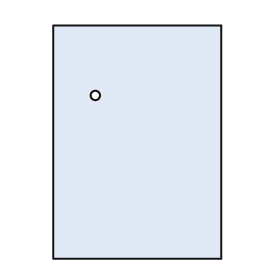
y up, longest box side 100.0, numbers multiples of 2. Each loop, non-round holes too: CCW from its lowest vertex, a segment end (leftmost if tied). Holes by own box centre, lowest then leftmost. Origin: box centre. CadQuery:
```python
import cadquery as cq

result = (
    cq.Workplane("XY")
    .moveTo(-36.0, -50.0)
    .lineTo(36.0, -50.0)
    .lineTo(36.0, 50.0)
    .lineTo(-36.0, 50.0)
    .close()
    .moveTo(-18.0, 20.0)
    .circle(2.0)
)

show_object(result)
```